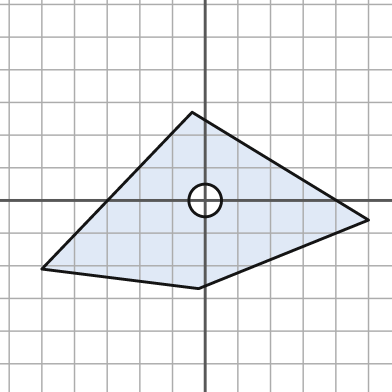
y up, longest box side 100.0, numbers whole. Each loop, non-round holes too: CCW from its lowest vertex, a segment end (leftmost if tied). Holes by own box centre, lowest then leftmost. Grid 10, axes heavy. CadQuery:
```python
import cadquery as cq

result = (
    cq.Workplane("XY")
    .moveTo(-2.0, -27.0)
    .lineTo(50.0, -6.0)
    .lineTo(-4.0, 27.0)
    .lineTo(-50.0, -21.0)
    .close()
    .moveTo(0.0, 0.0)
    .circle(5.0)
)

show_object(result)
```